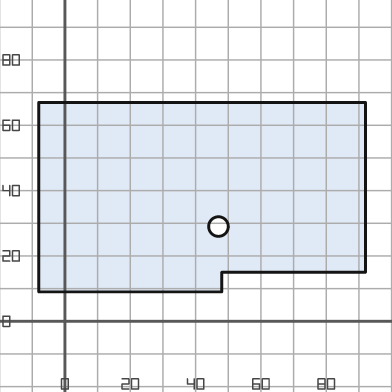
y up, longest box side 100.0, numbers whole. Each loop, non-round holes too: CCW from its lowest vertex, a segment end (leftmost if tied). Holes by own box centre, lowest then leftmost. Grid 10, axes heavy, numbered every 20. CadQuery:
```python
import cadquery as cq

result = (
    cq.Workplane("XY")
    .moveTo(-8.0, 9.0)
    .lineTo(48.0, 9.0)
    .lineTo(48.0, 15.0)
    .lineTo(92.0, 15.0)
    .lineTo(92.0, 67.0)
    .lineTo(-8.0, 67.0)
    .close()
    .moveTo(47.0, 29.0)
    .circle(3.0)
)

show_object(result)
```